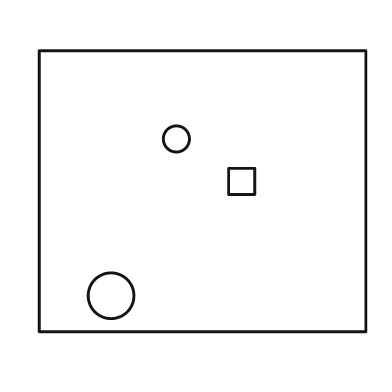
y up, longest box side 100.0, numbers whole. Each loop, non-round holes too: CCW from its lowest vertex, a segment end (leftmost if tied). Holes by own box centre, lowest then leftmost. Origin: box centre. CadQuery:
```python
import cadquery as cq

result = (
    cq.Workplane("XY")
    .moveTo(-50.0, -43.0)
    .lineTo(50.0, -43.0)
    .lineTo(50.0, 43.0)
    .lineTo(-50.0, 43.0)
    .close()
    .moveTo(-28.0, -32.0)
    .circle(7.0)
    .moveTo(8.0, -1.0)
    .lineTo(16.0, -1.0)
    .lineTo(16.0, 7.0)
    .lineTo(8.0, 7.0)
    .close()
    .moveTo(-8.0, 16.0)
    .circle(4.0)
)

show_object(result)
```